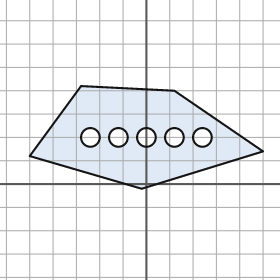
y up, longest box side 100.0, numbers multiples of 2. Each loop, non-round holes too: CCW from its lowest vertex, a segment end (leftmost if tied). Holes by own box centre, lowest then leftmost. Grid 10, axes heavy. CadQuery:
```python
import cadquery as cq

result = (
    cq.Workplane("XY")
    .moveTo(-2.0, -2.0)
    .lineTo(50.0, 14.0)
    .lineTo(12.0, 40.0)
    .lineTo(-28.0, 42.0)
    .lineTo(-50.0, 12.0)
    .close()
    .moveTo(-24.0, 20.0)
    .circle(4.0)
    .moveTo(-12.0, 20.0)
    .circle(4.0)
    .moveTo(0.0, 20.0)
    .circle(4.0)
    .moveTo(12.0, 20.0)
    .circle(4.0)
    .moveTo(24.0, 20.0)
    .circle(4.0)
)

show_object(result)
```